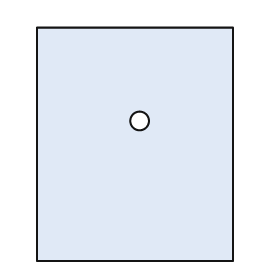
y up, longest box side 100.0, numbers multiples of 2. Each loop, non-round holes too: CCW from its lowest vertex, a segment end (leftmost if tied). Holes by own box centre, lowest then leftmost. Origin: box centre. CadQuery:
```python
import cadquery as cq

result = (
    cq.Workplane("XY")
    .moveTo(-42.0, -50.0)
    .lineTo(42.0, -50.0)
    .lineTo(42.0, 50.0)
    .lineTo(-42.0, 50.0)
    .close()
    .moveTo(2.0, 10.0)
    .circle(4.0)
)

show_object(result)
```